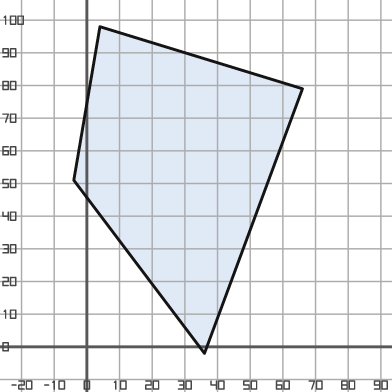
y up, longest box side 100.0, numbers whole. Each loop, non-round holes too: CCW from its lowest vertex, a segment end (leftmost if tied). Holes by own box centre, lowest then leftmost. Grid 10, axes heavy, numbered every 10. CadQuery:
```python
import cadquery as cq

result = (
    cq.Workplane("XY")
    .moveTo(36.0, -2.0)
    .lineTo(66.0, 79.0)
    .lineTo(4.0, 98.0)
    .lineTo(-4.0, 51.0)
    .close()
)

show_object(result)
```